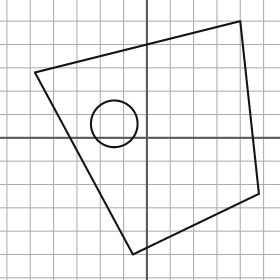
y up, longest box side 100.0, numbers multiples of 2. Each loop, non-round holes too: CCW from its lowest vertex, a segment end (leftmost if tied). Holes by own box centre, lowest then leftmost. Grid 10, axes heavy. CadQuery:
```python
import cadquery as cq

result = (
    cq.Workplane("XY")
    .moveTo(-6.0, -50.0)
    .lineTo(48.0, -24.0)
    .lineTo(40.0, 50.0)
    .lineTo(-48.0, 28.0)
    .close()
    .moveTo(-14.0, 6.0)
    .circle(10.0)
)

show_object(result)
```